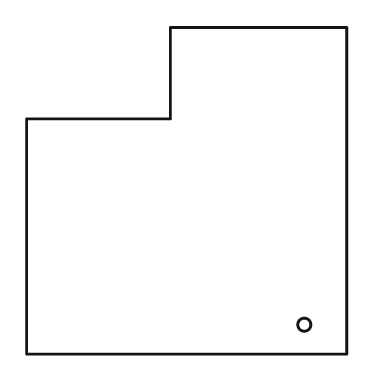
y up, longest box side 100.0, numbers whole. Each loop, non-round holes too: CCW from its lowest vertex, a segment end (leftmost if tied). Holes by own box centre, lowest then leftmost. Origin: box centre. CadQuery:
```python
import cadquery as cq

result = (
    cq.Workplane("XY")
    .moveTo(-49.0, -50.0)
    .lineTo(49.0, -50.0)
    .lineTo(49.0, 50.0)
    .lineTo(-5.0, 50.0)
    .lineTo(-5.0, 22.0)
    .lineTo(-49.0, 22.0)
    .close()
    .moveTo(36.0, -41.0)
    .circle(2.0)
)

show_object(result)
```